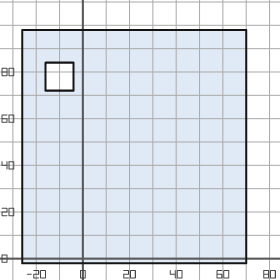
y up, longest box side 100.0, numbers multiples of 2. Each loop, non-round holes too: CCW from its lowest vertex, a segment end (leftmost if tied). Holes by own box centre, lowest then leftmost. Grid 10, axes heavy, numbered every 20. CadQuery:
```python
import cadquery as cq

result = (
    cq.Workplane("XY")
    .moveTo(-26.0, -2.0)
    .lineTo(70.0, -2.0)
    .lineTo(70.0, 98.0)
    .lineTo(-26.0, 98.0)
    .close()
    .moveTo(-16.0, 72.0)
    .lineTo(-4.0, 72.0)
    .lineTo(-4.0, 84.0)
    .lineTo(-16.0, 84.0)
    .close()
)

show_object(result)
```